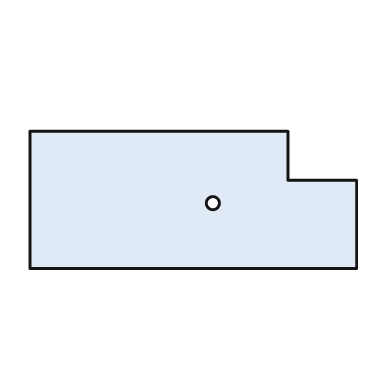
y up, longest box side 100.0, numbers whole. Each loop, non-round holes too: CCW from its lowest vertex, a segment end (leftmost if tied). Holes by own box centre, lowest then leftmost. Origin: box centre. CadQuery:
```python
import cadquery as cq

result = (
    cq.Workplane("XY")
    .moveTo(-50.0, -21.0)
    .lineTo(50.0, -21.0)
    .lineTo(50.0, 6.0)
    .lineTo(29.0, 6.0)
    .lineTo(29.0, 21.0)
    .lineTo(-50.0, 21.0)
    .close()
    .moveTo(6.0, -1.0)
    .circle(2.0)
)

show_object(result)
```